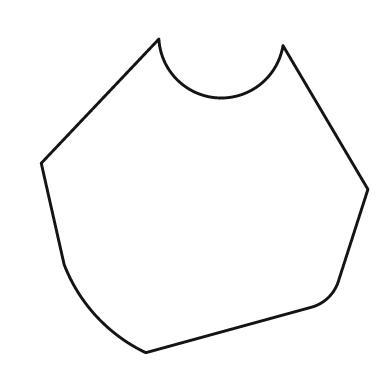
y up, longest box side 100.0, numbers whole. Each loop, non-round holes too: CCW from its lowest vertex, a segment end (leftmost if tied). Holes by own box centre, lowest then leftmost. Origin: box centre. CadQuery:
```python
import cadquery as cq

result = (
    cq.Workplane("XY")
    .moveTo(-18.0, -48.0)
    .lineTo(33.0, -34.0)
    .threePointArc((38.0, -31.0), (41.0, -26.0))
    .lineTo(50.0, 2.0)
    .lineTo(24.0, 46.0)
    .threePointArc((4.0, 30.0), (-14.0, 48.0))
    .lineTo(-50.0, 10.0)
    .lineTo(-43.0, -21.0)
    .threePointArc((-33.0, -37.0), (-18.0, -48.0))
    .close()
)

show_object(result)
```